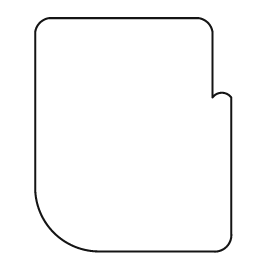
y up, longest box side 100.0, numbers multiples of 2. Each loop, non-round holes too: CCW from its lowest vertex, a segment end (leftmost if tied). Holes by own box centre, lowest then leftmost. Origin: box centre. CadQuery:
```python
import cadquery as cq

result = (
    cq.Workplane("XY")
    .moveTo(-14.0, -50.0)
    .lineTo(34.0, -50.0)
    .threePointArc((40.0, -48.0), (42.0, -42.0))
    .lineTo(42.0, 16.0)
    .threePointArc((38.0, 18.0), (34.0, 16.0))
    .lineTo(34.0, 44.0)
    .threePointArc((32.0, 48.0), (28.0, 50.0))
    .lineTo(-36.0, 50.0)
    .threePointArc((-40.0, 48.0), (-42.0, 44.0))
    .lineTo(-42.0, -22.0)
    .threePointArc((-34.0, -42.0), (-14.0, -50.0))
    .close()
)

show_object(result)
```